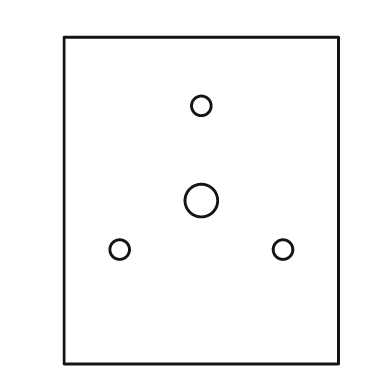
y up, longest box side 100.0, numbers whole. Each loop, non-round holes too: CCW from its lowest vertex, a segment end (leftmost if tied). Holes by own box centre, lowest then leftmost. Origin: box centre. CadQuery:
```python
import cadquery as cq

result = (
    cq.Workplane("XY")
    .moveTo(-42.0, -50.0)
    .lineTo(42.0, -50.0)
    .lineTo(42.0, 50.0)
    .lineTo(-42.0, 50.0)
    .close()
    .moveTo(-25.0, -15.0)
    .circle(3.0)
    .moveTo(25.0, -15.0)
    .circle(3.0)
    .moveTo(0.0, 0.0)
    .circle(5.0)
    .moveTo(0.0, 29.0)
    .circle(3.0)
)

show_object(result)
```